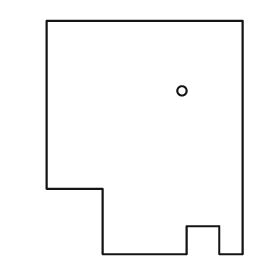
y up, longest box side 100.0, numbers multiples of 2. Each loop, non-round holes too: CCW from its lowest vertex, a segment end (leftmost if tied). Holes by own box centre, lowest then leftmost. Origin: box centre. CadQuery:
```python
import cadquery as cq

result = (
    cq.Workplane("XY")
    .moveTo(-18.0, -50.0)
    .lineTo(18.0, -50.0)
    .lineTo(18.0, -38.0)
    .lineTo(32.0, -38.0)
    .lineTo(32.0, -50.0)
    .lineTo(42.0, -50.0)
    .lineTo(42.0, 50.0)
    .lineTo(-42.0, 50.0)
    .lineTo(-42.0, -22.0)
    .lineTo(-18.0, -22.0)
    .close()
    .moveTo(16.0, 20.0)
    .circle(2.0)
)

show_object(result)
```